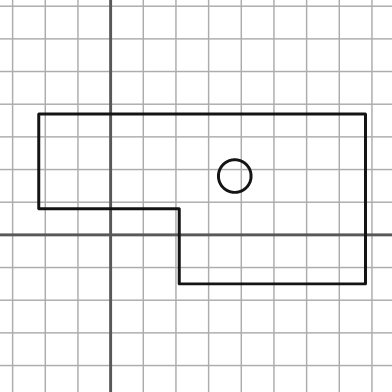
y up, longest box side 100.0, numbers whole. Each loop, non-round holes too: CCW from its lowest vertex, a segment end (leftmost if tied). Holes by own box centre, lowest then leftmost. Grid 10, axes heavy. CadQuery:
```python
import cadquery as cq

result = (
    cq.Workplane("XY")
    .moveTo(21.0, -15.0)
    .lineTo(78.0, -15.0)
    .lineTo(78.0, 37.0)
    .lineTo(-22.0, 37.0)
    .lineTo(-22.0, 8.0)
    .lineTo(21.0, 8.0)
    .close()
    .moveTo(38.0, 18.0)
    .circle(5.0)
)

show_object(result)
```